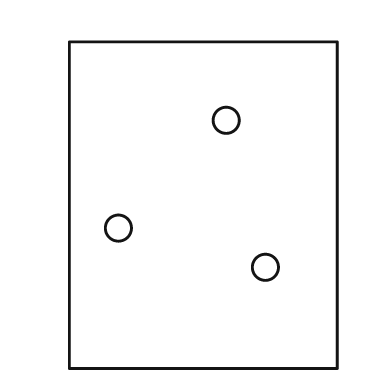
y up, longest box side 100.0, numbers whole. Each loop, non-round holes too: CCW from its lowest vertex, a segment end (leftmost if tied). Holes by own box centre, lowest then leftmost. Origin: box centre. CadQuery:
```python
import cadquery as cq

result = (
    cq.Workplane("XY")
    .moveTo(-41.0, -50.0)
    .lineTo(41.0, -50.0)
    .lineTo(41.0, 50.0)
    .lineTo(-41.0, 50.0)
    .close()
    .moveTo(19.0, -19.0)
    .circle(4.0)
    .moveTo(-26.0, -7.0)
    .circle(4.0)
    .moveTo(7.0, 26.0)
    .circle(4.0)
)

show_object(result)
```